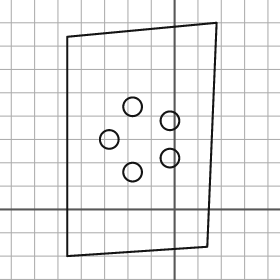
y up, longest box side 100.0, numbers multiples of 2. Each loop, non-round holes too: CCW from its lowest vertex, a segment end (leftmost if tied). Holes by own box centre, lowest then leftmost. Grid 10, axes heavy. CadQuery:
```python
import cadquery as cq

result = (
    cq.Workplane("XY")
    .moveTo(-46.0, -20.0)
    .lineTo(14.0, -16.0)
    .lineTo(18.0, 80.0)
    .lineTo(-46.0, 74.0)
    .close()
    .moveTo(-18.0, 16.0)
    .circle(4.0)
    .moveTo(-2.0, 22.0)
    .circle(4.0)
    .moveTo(-28.0, 30.0)
    .circle(4.0)
    .moveTo(-2.0, 38.0)
    .circle(4.0)
    .moveTo(-18.0, 44.0)
    .circle(4.0)
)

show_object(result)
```